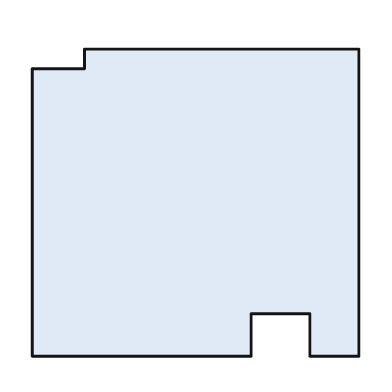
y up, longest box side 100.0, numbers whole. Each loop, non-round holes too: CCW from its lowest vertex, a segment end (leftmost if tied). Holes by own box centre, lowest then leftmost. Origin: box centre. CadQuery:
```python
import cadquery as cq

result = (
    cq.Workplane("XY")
    .moveTo(-50.0, -47.0)
    .lineTo(17.0, -47.0)
    .lineTo(17.0, -34.0)
    .lineTo(35.0, -34.0)
    .lineTo(35.0, -47.0)
    .lineTo(50.0, -47.0)
    .lineTo(50.0, 47.0)
    .lineTo(-34.0, 47.0)
    .lineTo(-34.0, 41.0)
    .lineTo(-50.0, 41.0)
    .close()
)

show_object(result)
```